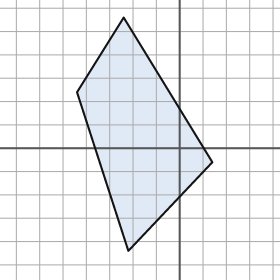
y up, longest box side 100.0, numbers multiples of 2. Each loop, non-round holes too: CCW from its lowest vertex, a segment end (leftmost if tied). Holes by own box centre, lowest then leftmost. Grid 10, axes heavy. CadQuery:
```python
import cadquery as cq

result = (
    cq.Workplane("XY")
    .moveTo(-22.0, -44.0)
    .lineTo(14.0, -6.0)
    .lineTo(-24.0, 56.0)
    .lineTo(-44.0, 24.0)
    .close()
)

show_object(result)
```